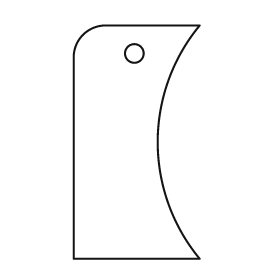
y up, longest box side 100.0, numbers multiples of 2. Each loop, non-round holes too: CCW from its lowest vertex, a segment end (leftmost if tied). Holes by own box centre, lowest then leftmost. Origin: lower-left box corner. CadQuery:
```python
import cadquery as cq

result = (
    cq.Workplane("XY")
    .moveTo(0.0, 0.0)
    .lineTo(54.0, 0.0)
    .threePointArc((36.0, 50.0), (54.0, 100.0))
    .lineTo(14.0, 100.0)
    .threePointArc((4.0, 96.0), (0.0, 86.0))
    .close()
    .moveTo(26.0, 88.0)
    .circle(4.0)
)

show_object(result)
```